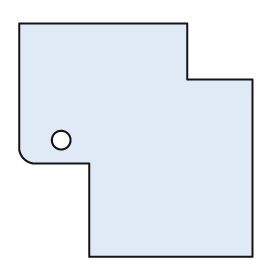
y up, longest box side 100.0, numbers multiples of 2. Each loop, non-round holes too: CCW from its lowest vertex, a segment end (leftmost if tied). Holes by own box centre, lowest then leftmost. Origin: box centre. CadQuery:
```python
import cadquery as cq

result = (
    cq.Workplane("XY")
    .moveTo(-20.0, -50.0)
    .lineTo(50.0, -50.0)
    .lineTo(50.0, 26.0)
    .lineTo(22.0, 26.0)
    .lineTo(22.0, 50.0)
    .lineTo(-50.0, 50.0)
    .lineTo(-50.0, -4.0)
    .threePointArc((-48.0, -8.0), (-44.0, -10.0))
    .lineTo(-20.0, -10.0)
    .close()
    .moveTo(-32.0, 0.0)
    .circle(4.0)
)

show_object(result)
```